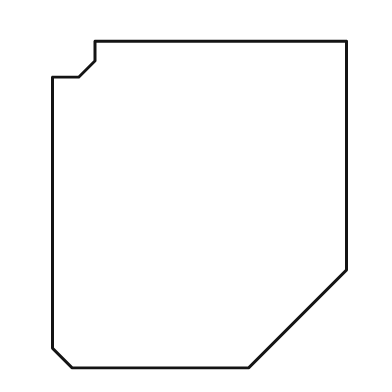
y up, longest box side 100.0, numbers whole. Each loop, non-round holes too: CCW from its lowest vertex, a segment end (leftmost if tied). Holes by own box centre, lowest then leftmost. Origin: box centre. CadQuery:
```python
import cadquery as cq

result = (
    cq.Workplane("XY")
    .moveTo(-39.0, -50.0)
    .lineTo(15.0, -50.0)
    .lineTo(45.0, -20.0)
    .lineTo(45.0, 50.0)
    .lineTo(-32.0, 50.0)
    .lineTo(-32.0, 44.0)
    .lineTo(-37.0, 39.0)
    .lineTo(-45.0, 39.0)
    .lineTo(-45.0, -44.0)
    .close()
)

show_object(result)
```